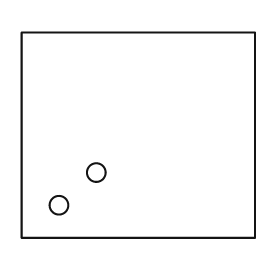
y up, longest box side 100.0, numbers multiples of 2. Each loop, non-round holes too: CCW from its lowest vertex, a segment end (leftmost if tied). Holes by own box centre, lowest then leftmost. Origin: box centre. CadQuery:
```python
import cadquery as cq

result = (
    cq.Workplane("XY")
    .moveTo(-50.0, -44.0)
    .lineTo(50.0, -44.0)
    .lineTo(50.0, 44.0)
    .lineTo(-50.0, 44.0)
    .close()
    .moveTo(-34.0, -30.0)
    .circle(4.0)
    .moveTo(-18.0, -16.0)
    .circle(4.0)
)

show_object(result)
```